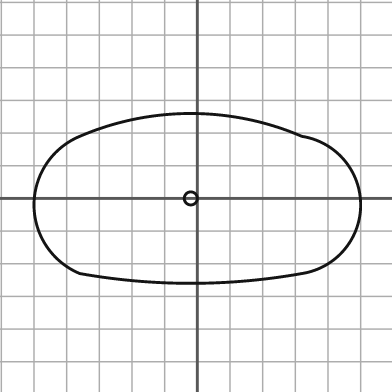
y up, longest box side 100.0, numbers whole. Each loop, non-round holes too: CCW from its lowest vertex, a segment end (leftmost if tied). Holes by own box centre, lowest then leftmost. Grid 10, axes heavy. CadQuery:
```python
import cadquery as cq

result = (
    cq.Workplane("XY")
    .moveTo(-36.0, -23.0)
    .threePointArc((-2.0, -26.0), (32.0, -23.0))
    .threePointArc((50.0, -2.0), (32.0, 19.0))
    .threePointArc((-2.0, 26.0), (-36.0, 19.0))
    .threePointArc((-50.0, -2.0), (-36.0, -23.0))
    .close()
    .moveTo(-2.0, 0.0)
    .circle(2.0)
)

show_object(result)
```